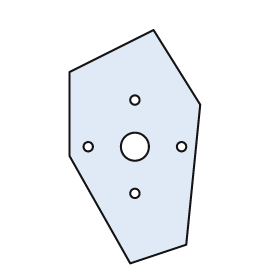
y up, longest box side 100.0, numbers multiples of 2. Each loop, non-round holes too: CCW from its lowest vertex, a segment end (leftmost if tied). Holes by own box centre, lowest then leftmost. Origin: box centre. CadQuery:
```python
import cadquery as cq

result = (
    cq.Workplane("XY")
    .moveTo(-2.0, -50.0)
    .lineTo(22.0, -42.0)
    .lineTo(28.0, 18.0)
    .lineTo(8.0, 50.0)
    .lineTo(-28.0, 32.0)
    .lineTo(-28.0, -4.0)
    .close()
    .moveTo(0.0, -20.0)
    .circle(2.0)
    .moveTo(-20.0, 0.0)
    .circle(2.0)
    .moveTo(0.0, 0.0)
    .circle(6.0)
    .moveTo(20.0, 0.0)
    .circle(2.0)
    .moveTo(0.0, 20.0)
    .circle(2.0)
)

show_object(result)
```